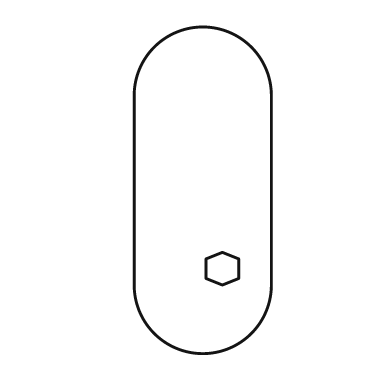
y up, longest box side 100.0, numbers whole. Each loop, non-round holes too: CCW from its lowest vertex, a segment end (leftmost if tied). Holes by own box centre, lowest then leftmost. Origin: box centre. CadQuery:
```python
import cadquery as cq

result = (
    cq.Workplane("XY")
    .moveTo(-21.0, -29.0)
    .threePointArc((0.0, -50.0), (21.0, -29.0))
    .lineTo(21.0, 29.0)
    .threePointArc((0.0, 50.0), (-21.0, 29.0))
    .close()
    .moveTo(6.0, -29.0)
    .lineTo(11.0, -27.0)
    .lineTo(11.0, -21.0)
    .lineTo(6.0, -19.0)
    .lineTo(1.0, -21.0)
    .lineTo(1.0, -27.0)
    .close()
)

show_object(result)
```